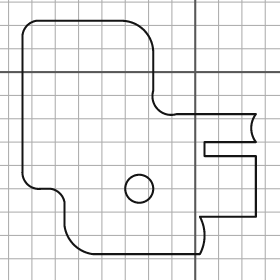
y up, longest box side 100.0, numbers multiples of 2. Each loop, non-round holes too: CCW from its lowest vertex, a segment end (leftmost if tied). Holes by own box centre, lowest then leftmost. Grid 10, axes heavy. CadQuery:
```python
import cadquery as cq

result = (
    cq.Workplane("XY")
    .moveTo(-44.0, -78.0)
    .lineTo(2.0, -78.0)
    .threePointArc((4.0, -70.0), (2.0, -62.0))
    .lineTo(26.0, -62.0)
    .lineTo(26.0, -36.0)
    .lineTo(4.0, -36.0)
    .lineTo(4.0, -30.0)
    .lineTo(26.0, -30.0)
    .threePointArc((24.0, -24.0), (26.0, -18.0))
    .lineTo(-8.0, -18.0)
    .threePointArc((-16.0, -16.0), (-18.0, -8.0))
    .lineTo(-18.0, 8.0)
    .threePointArc((-22.0, 18.0), (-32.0, 22.0))
    .lineTo(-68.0, 22.0)
    .threePointArc((-72.0, 20.0), (-74.0, 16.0))
    .lineTo(-74.0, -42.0)
    .threePointArc((-72.0, -48.0), (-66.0, -50.0))
    .lineTo(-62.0, -50.0)
    .threePointArc((-58.0, -52.0), (-56.0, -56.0))
    .lineTo(-56.0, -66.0)
    .threePointArc((-52.0, -74.0), (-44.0, -78.0))
    .close()
    .moveTo(-24.0, -50.0)
    .circle(6.0)
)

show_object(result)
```